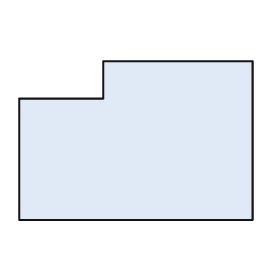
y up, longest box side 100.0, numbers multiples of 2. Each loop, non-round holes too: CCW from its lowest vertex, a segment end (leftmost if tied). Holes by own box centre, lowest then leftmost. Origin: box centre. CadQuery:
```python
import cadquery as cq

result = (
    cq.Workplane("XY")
    .moveTo(-50.0, -34.0)
    .lineTo(50.0, -34.0)
    .lineTo(50.0, 34.0)
    .lineTo(-14.0, 34.0)
    .lineTo(-14.0, 18.0)
    .lineTo(-50.0, 18.0)
    .close()
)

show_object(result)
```